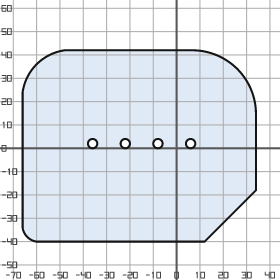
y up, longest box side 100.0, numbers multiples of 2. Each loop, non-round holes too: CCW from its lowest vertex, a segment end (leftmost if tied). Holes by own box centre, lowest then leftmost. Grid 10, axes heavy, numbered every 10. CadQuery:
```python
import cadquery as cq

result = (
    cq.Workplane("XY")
    .moveTo(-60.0, -40.0)
    .lineTo(12.0, -40.0)
    .lineTo(34.0, -18.0)
    .lineTo(34.0, 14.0)
    .threePointArc((26.0, 34.0), (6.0, 42.0))
    .lineTo(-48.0, 42.0)
    .threePointArc((-60.0, 36.0), (-66.0, 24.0))
    .lineTo(-66.0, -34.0)
    .threePointArc((-64.0, -38.0), (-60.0, -40.0))
    .close()
    .moveTo(-36.0, 2.0)
    .circle(2.0)
    .moveTo(-22.0, 2.0)
    .circle(2.0)
    .moveTo(-8.0, 2.0)
    .circle(2.0)
    .moveTo(6.0, 2.0)
    .circle(2.0)
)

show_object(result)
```